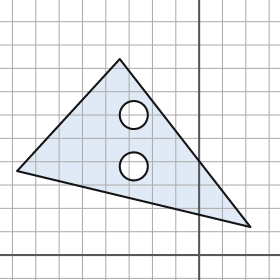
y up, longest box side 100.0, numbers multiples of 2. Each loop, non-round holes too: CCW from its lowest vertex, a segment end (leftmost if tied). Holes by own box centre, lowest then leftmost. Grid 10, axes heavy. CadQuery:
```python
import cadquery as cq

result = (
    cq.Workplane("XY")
    .moveTo(22.0, 12.0)
    .lineTo(-34.0, 84.0)
    .lineTo(-78.0, 36.0)
    .close()
    .moveTo(-28.0, 38.0)
    .circle(6.0)
    .moveTo(-28.0, 60.0)
    .circle(6.0)
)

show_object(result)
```